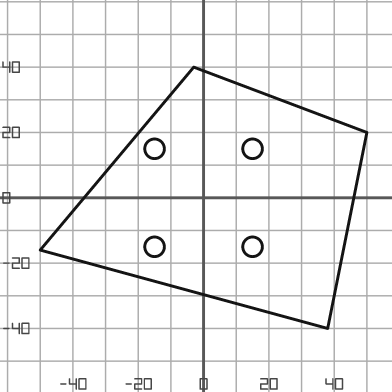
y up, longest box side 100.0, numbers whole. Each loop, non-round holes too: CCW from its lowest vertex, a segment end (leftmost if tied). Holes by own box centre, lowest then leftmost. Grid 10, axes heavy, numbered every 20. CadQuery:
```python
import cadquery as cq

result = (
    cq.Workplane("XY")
    .moveTo(38.0, -40.0)
    .lineTo(50.0, 20.0)
    .lineTo(-3.0, 40.0)
    .lineTo(-50.0, -16.0)
    .close()
    .moveTo(-15.0, -15.0)
    .circle(3.0)
    .moveTo(15.0, -15.0)
    .circle(3.0)
    .moveTo(-15.0, 15.0)
    .circle(3.0)
    .moveTo(15.0, 15.0)
    .circle(3.0)
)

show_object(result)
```